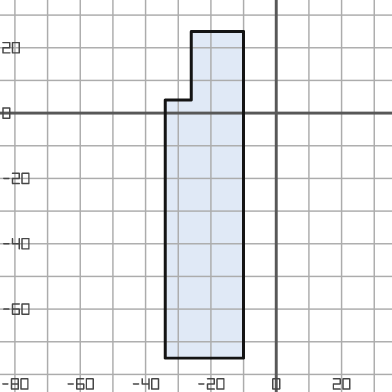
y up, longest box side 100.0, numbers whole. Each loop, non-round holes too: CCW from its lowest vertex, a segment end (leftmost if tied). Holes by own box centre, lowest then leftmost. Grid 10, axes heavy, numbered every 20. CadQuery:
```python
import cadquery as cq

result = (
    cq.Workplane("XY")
    .moveTo(-34.0, -75.0)
    .lineTo(-10.0, -75.0)
    .lineTo(-10.0, 25.0)
    .lineTo(-26.0, 25.0)
    .lineTo(-26.0, 4.0)
    .lineTo(-34.0, 4.0)
    .close()
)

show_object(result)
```